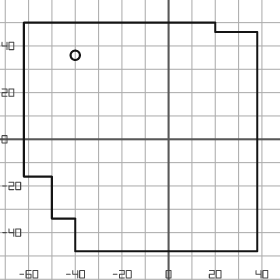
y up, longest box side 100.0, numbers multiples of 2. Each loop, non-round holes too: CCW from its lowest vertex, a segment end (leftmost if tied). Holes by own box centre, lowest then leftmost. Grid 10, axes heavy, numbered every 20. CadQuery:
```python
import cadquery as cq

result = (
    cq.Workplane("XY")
    .moveTo(-40.0, -48.0)
    .lineTo(38.0, -48.0)
    .lineTo(38.0, 46.0)
    .lineTo(20.0, 46.0)
    .lineTo(20.0, 50.0)
    .lineTo(-62.0, 50.0)
    .lineTo(-62.0, -16.0)
    .lineTo(-50.0, -16.0)
    .lineTo(-50.0, -34.0)
    .lineTo(-40.0, -34.0)
    .close()
    .moveTo(-40.0, 36.0)
    .circle(2.0)
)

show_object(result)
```